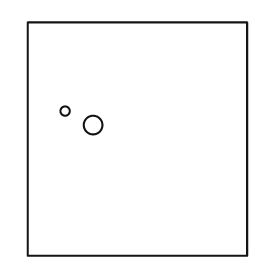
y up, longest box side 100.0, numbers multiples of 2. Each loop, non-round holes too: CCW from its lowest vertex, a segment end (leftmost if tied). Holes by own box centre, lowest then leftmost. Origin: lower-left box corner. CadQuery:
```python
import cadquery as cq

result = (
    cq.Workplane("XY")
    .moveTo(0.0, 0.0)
    .lineTo(94.0, 0.0)
    .lineTo(94.0, 100.0)
    .lineTo(0.0, 100.0)
    .close()
    .moveTo(28.0, 56.0)
    .circle(4.0)
    .moveTo(16.0, 62.0)
    .circle(2.0)
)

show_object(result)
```